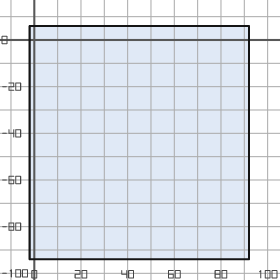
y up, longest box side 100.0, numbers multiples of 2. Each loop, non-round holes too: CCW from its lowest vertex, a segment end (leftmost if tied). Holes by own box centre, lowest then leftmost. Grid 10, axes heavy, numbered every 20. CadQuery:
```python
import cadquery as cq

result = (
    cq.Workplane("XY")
    .moveTo(-2.0, -94.0)
    .lineTo(92.0, -94.0)
    .lineTo(92.0, 6.0)
    .lineTo(-2.0, 6.0)
    .close()
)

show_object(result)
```